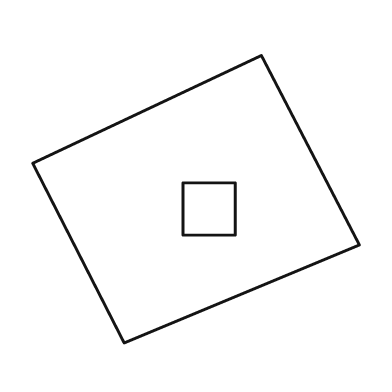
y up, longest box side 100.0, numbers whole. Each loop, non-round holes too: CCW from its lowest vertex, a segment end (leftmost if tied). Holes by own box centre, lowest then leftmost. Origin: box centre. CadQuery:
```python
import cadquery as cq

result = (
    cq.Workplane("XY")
    .moveTo(-22.0, -44.0)
    .lineTo(50.0, -14.0)
    .lineTo(20.0, 44.0)
    .lineTo(-50.0, 11.0)
    .close()
    .moveTo(-4.0, -11.0)
    .lineTo(12.0, -11.0)
    .lineTo(12.0, 5.0)
    .lineTo(-4.0, 5.0)
    .close()
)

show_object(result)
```